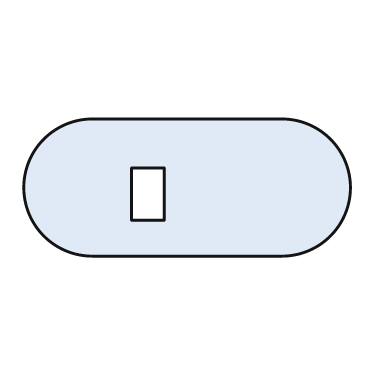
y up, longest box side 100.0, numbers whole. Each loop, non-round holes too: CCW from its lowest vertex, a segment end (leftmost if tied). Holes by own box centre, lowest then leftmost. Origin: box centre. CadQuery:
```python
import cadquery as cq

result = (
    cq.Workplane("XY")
    .moveTo(-29.0, -21.0)
    .lineTo(29.0, -21.0)
    .threePointArc((50.0, 0.0), (29.0, 21.0))
    .lineTo(-29.0, 21.0)
    .threePointArc((-50.0, 0.0), (-29.0, -21.0))
    .close()
    .moveTo(-17.0, -10.0)
    .lineTo(-7.0, -10.0)
    .lineTo(-7.0, 6.0)
    .lineTo(-17.0, 6.0)
    .close()
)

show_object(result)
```